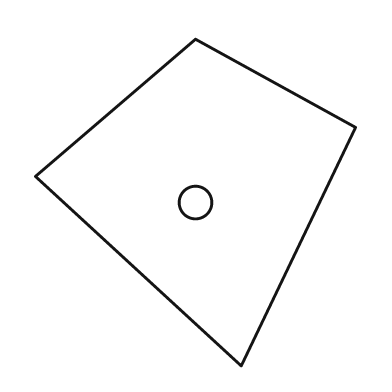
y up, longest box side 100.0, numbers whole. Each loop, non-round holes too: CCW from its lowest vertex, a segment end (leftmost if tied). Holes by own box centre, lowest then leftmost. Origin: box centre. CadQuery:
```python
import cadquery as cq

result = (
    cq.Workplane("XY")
    .moveTo(14.0, -50.0)
    .lineTo(49.0, 23.0)
    .lineTo(0.0, 50.0)
    .lineTo(-49.0, 8.0)
    .close()
    .moveTo(0.0, 0.0)
    .circle(5.0)
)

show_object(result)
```